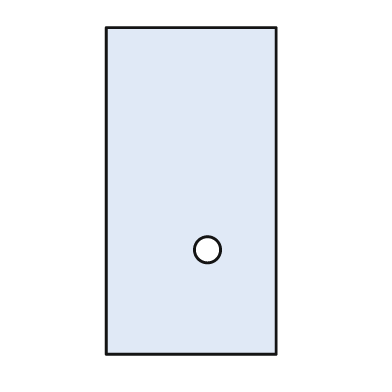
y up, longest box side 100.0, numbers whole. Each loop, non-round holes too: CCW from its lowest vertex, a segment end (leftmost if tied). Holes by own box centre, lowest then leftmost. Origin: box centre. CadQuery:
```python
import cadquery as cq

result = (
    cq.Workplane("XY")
    .moveTo(-26.0, -50.0)
    .lineTo(26.0, -50.0)
    .lineTo(26.0, 50.0)
    .lineTo(-26.0, 50.0)
    .close()
    .moveTo(5.0, -18.0)
    .circle(4.0)
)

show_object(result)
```